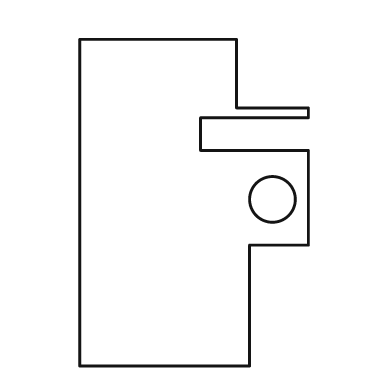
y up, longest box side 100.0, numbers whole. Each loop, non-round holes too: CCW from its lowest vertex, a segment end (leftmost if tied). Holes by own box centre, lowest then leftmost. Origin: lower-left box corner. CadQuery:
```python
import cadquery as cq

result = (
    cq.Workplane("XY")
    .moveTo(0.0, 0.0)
    .lineTo(52.0, 0.0)
    .lineTo(52.0, 37.0)
    .lineTo(70.0, 37.0)
    .lineTo(70.0, 66.0)
    .lineTo(37.0, 66.0)
    .lineTo(37.0, 76.0)
    .lineTo(70.0, 76.0)
    .lineTo(70.0, 79.0)
    .lineTo(48.0, 79.0)
    .lineTo(48.0, 100.0)
    .lineTo(0.0, 100.0)
    .close()
    .moveTo(59.0, 51.0)
    .circle(7.0)
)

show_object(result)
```